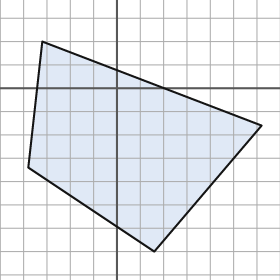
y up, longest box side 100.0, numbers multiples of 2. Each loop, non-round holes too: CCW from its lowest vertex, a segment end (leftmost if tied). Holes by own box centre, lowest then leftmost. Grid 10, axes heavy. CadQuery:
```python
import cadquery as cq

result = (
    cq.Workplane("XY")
    .moveTo(16.0, -70.0)
    .lineTo(62.0, -16.0)
    .lineTo(-32.0, 20.0)
    .lineTo(-38.0, -34.0)
    .close()
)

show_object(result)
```